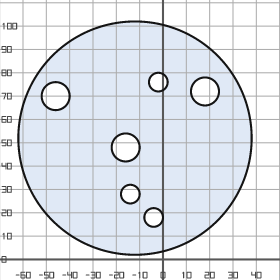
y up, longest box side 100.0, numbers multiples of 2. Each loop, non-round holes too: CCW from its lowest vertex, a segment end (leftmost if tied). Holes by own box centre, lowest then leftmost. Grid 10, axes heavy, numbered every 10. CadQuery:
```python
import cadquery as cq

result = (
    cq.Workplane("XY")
    .moveTo(-12.0, 52.0)
    .circle(50.0)
    .moveTo(-4.0, 18.0)
    .circle(4.0)
    .moveTo(-14.0, 28.0)
    .circle(4.0)
    .moveTo(-16.0, 48.0)
    .circle(6.0)
    .moveTo(-46.0, 70.0)
    .circle(6.0)
    .moveTo(18.0, 72.0)
    .circle(6.0)
    .moveTo(-2.0, 76.0)
    .circle(4.0)
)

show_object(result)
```